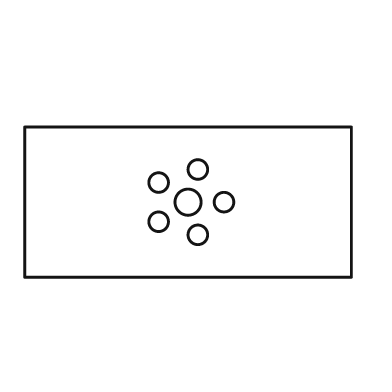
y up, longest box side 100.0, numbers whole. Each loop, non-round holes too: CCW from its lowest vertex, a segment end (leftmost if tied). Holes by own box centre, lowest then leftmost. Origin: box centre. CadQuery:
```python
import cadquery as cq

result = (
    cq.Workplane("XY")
    .moveTo(-50.0, -23.0)
    .lineTo(50.0, -23.0)
    .lineTo(50.0, 23.0)
    .lineTo(-50.0, 23.0)
    .close()
    .moveTo(3.0, -10.0)
    .circle(3.0)
    .moveTo(-9.0, -6.0)
    .circle(3.0)
    .moveTo(0.0, 0.0)
    .circle(4.0)
    .moveTo(11.0, 0.0)
    .circle(3.0)
    .moveTo(-9.0, 6.0)
    .circle(3.0)
    .moveTo(3.0, 10.0)
    .circle(3.0)
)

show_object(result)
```